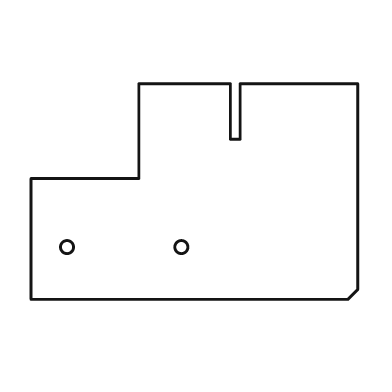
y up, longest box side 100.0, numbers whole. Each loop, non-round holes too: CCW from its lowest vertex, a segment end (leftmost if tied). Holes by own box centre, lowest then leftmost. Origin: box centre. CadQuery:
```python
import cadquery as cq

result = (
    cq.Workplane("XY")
    .moveTo(-50.0, -33.0)
    .lineTo(47.0, -33.0)
    .lineTo(50.0, -30.0)
    .lineTo(50.0, 33.0)
    .lineTo(14.0, 33.0)
    .lineTo(14.0, 16.0)
    .lineTo(11.0, 16.0)
    .lineTo(11.0, 33.0)
    .lineTo(-17.0, 33.0)
    .lineTo(-17.0, 4.0)
    .lineTo(-50.0, 4.0)
    .close()
    .moveTo(-39.0, -17.0)
    .circle(2.0)
    .moveTo(-4.0, -17.0)
    .circle(2.0)
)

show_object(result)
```